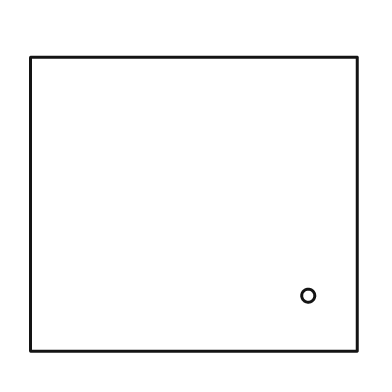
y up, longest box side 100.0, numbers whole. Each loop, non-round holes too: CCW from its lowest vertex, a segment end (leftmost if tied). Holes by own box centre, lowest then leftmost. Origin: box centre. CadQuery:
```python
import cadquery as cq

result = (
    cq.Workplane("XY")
    .moveTo(-50.0, -45.0)
    .lineTo(50.0, -45.0)
    .lineTo(50.0, 45.0)
    .lineTo(-50.0, 45.0)
    .close()
    .moveTo(35.0, -28.0)
    .circle(2.0)
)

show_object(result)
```